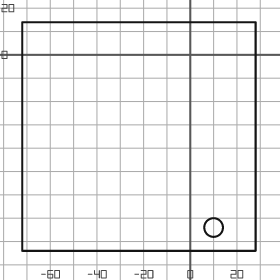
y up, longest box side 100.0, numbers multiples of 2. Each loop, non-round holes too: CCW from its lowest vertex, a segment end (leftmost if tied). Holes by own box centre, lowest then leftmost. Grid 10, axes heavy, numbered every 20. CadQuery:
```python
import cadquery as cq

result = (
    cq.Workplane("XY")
    .moveTo(-72.0, -84.0)
    .lineTo(28.0, -84.0)
    .lineTo(28.0, 14.0)
    .lineTo(-72.0, 14.0)
    .close()
    .moveTo(10.0, -74.0)
    .circle(4.0)
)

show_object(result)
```